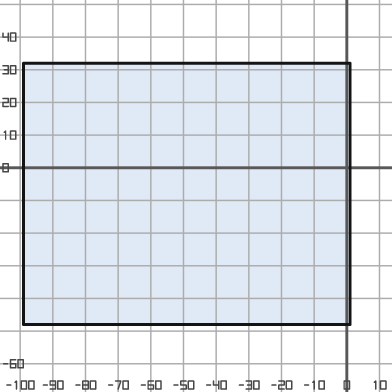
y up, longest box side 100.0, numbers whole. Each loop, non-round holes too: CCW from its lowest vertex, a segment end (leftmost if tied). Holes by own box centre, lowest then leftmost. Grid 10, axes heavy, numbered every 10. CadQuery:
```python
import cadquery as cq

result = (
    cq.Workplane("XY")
    .moveTo(-99.0, -48.0)
    .lineTo(1.0, -48.0)
    .lineTo(1.0, 32.0)
    .lineTo(-99.0, 32.0)
    .close()
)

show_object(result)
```